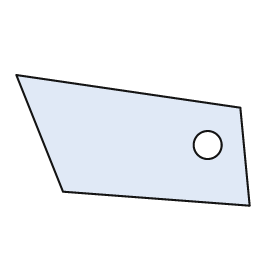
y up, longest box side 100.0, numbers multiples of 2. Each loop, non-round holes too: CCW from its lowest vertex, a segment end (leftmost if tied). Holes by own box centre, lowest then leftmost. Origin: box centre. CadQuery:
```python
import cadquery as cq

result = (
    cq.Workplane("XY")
    .moveTo(50.0, -28.0)
    .lineTo(46.0, 14.0)
    .lineTo(-50.0, 28.0)
    .lineTo(-30.0, -22.0)
    .close()
    .moveTo(32.0, -2.0)
    .circle(6.0)
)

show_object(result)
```